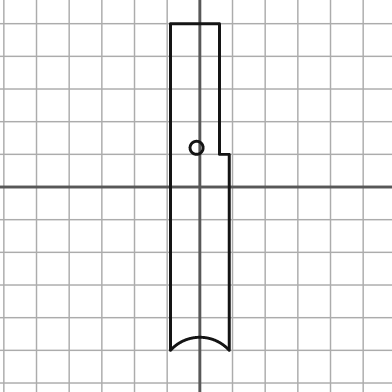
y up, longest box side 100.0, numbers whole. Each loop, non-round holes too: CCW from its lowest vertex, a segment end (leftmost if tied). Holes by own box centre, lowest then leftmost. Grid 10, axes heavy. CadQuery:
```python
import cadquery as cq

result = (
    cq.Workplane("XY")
    .moveTo(-9.0, -50.0)
    .threePointArc((0.0, -46.0), (9.0, -50.0))
    .lineTo(9.0, 10.0)
    .lineTo(6.0, 10.0)
    .lineTo(6.0, 50.0)
    .lineTo(-9.0, 50.0)
    .close()
    .moveTo(-1.0, 12.0)
    .circle(2.0)
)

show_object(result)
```